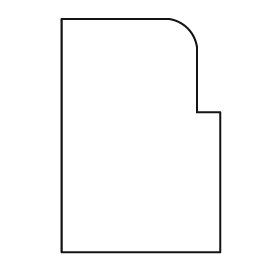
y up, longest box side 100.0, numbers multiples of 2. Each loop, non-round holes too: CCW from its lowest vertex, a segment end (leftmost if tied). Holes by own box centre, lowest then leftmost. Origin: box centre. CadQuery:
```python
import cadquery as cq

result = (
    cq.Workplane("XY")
    .moveTo(-34.0, -50.0)
    .lineTo(34.0, -50.0)
    .lineTo(34.0, 10.0)
    .lineTo(24.0, 10.0)
    .lineTo(24.0, 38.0)
    .threePointArc((20.0, 46.0), (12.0, 50.0))
    .lineTo(-34.0, 50.0)
    .close()
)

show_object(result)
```